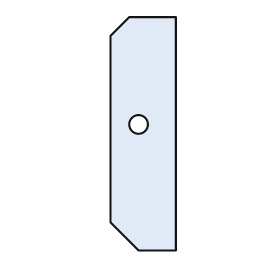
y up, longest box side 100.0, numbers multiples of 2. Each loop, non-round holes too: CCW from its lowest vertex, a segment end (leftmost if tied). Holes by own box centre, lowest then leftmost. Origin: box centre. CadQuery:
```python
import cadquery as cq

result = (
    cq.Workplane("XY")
    .moveTo(-2.0, -50.0)
    .lineTo(14.0, -50.0)
    .lineTo(14.0, 50.0)
    .lineTo(-6.0, 50.0)
    .lineTo(-14.0, 42.0)
    .lineTo(-14.0, -38.0)
    .close()
    .moveTo(-2.0, 4.0)
    .circle(4.0)
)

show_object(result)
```